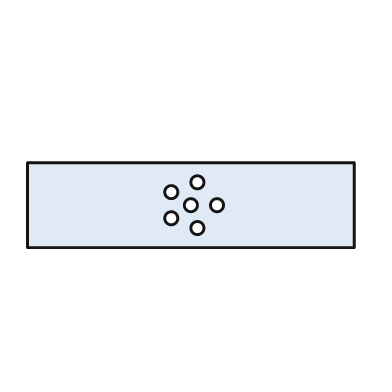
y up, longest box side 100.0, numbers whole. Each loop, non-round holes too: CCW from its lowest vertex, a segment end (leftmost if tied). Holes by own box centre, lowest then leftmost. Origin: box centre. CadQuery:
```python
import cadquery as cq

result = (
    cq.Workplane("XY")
    .moveTo(-50.0, -13.0)
    .lineTo(50.0, -13.0)
    .lineTo(50.0, 13.0)
    .lineTo(-50.0, 13.0)
    .close()
    .moveTo(2.0, -7.0)
    .circle(2.0)
    .moveTo(-6.0, -4.0)
    .circle(2.0)
    .moveTo(0.0, 0.0)
    .circle(2.0)
    .moveTo(8.0, 0.0)
    .circle(2.0)
    .moveTo(-6.0, 4.0)
    .circle(2.0)
    .moveTo(2.0, 7.0)
    .circle(2.0)
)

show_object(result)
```